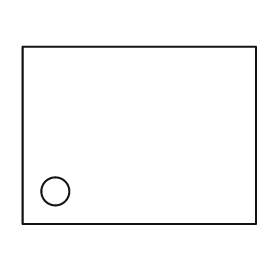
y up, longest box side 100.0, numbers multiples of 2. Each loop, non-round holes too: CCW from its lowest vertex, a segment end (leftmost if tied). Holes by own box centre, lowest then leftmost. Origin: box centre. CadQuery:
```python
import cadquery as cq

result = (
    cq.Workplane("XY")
    .moveTo(-50.0, -38.0)
    .lineTo(50.0, -38.0)
    .lineTo(50.0, 38.0)
    .lineTo(-50.0, 38.0)
    .close()
    .moveTo(-36.0, -24.0)
    .circle(6.0)
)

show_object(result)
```